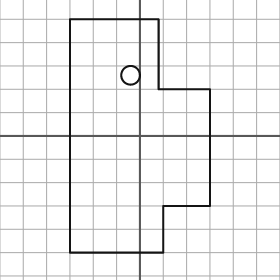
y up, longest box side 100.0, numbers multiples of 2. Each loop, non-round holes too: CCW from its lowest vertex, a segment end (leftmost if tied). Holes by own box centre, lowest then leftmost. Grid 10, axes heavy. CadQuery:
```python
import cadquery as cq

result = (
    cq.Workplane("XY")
    .moveTo(-30.0, -50.0)
    .lineTo(10.0, -50.0)
    .lineTo(10.0, -30.0)
    .lineTo(30.0, -30.0)
    .lineTo(30.0, 20.0)
    .lineTo(8.0, 20.0)
    .lineTo(8.0, 50.0)
    .lineTo(-30.0, 50.0)
    .close()
    .moveTo(-4.0, 26.0)
    .circle(4.0)
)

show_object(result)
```